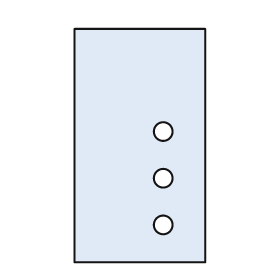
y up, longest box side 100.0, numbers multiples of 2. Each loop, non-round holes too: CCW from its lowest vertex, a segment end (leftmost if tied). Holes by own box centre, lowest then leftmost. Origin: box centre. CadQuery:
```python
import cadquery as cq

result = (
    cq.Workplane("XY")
    .moveTo(-28.0, -50.0)
    .lineTo(28.0, -50.0)
    .lineTo(28.0, 50.0)
    .lineTo(-28.0, 50.0)
    .close()
    .moveTo(10.0, -34.0)
    .circle(4.0)
    .moveTo(10.0, -14.0)
    .circle(4.0)
    .moveTo(10.0, 6.0)
    .circle(4.0)
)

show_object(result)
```